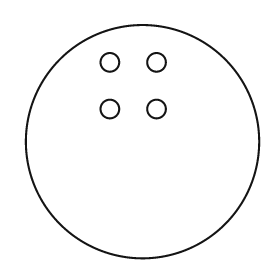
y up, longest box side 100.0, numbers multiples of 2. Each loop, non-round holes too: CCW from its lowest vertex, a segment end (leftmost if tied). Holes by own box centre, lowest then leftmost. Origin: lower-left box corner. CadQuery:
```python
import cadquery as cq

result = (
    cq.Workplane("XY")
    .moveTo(50.0, 50.0)
    .circle(50.0)
    .moveTo(36.0, 64.0)
    .circle(4.0)
    .moveTo(56.0, 64.0)
    .circle(4.0)
    .moveTo(36.0, 84.0)
    .circle(4.0)
    .moveTo(56.0, 84.0)
    .circle(4.0)
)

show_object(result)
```